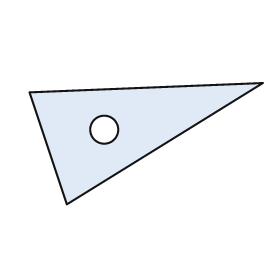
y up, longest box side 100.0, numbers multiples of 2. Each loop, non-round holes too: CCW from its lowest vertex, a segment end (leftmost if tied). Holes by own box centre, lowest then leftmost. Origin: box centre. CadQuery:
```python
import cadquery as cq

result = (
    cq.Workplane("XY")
    .moveTo(-34.0, -26.0)
    .lineTo(50.0, 26.0)
    .lineTo(-50.0, 22.0)
    .close()
    .moveTo(-18.0, 6.0)
    .circle(6.0)
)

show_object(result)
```